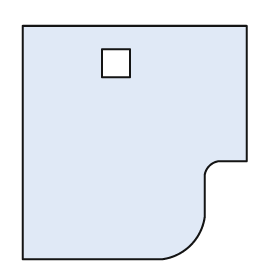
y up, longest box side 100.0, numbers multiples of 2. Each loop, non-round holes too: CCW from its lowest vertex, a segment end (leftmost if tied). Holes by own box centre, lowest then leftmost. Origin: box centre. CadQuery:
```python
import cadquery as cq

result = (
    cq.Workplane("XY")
    .moveTo(-48.0, -50.0)
    .lineTo(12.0, -50.0)
    .threePointArc((24.0, -44.0), (30.0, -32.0))
    .lineTo(30.0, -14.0)
    .threePointArc((32.0, -10.0), (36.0, -8.0))
    .lineTo(48.0, -8.0)
    .lineTo(48.0, 50.0)
    .lineTo(-48.0, 50.0)
    .close()
    .moveTo(-14.0, 28.0)
    .lineTo(-2.0, 28.0)
    .lineTo(-2.0, 40.0)
    .lineTo(-14.0, 40.0)
    .close()
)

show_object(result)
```